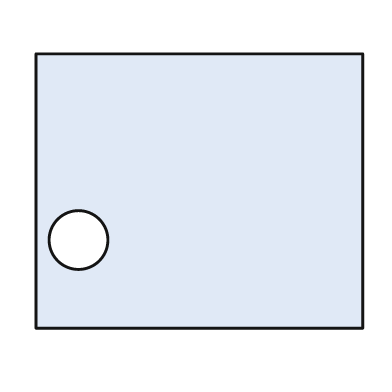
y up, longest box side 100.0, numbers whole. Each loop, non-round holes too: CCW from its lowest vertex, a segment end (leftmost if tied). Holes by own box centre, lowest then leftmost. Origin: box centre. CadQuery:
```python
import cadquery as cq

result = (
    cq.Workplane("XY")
    .moveTo(-50.0, -42.0)
    .lineTo(50.0, -42.0)
    .lineTo(50.0, 42.0)
    .lineTo(-50.0, 42.0)
    .close()
    .moveTo(-37.0, -15.0)
    .circle(9.0)
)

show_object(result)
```